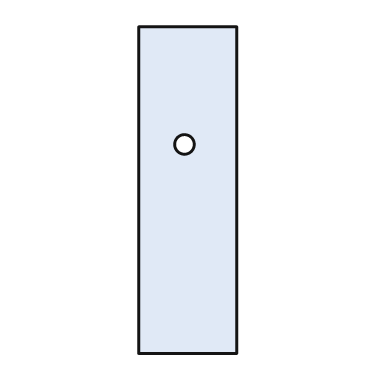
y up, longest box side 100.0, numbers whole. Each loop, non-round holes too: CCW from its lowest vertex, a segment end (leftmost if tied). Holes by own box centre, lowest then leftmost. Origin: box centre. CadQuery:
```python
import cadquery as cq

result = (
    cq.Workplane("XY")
    .moveTo(-15.0, -50.0)
    .lineTo(15.0, -50.0)
    .lineTo(15.0, 50.0)
    .lineTo(-15.0, 50.0)
    .close()
    .moveTo(-1.0, 14.0)
    .circle(3.0)
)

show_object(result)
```